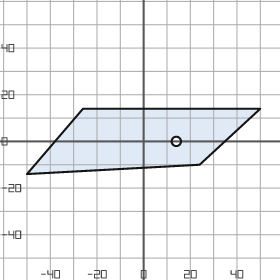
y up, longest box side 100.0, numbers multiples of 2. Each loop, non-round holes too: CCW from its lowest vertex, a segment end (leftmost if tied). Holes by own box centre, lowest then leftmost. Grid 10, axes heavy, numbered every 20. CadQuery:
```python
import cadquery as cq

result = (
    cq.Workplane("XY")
    .moveTo(-50.0, -14.0)
    .lineTo(24.0, -10.0)
    .lineTo(50.0, 14.0)
    .lineTo(-26.0, 14.0)
    .close()
    .moveTo(14.0, 0.0)
    .circle(2.0)
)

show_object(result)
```